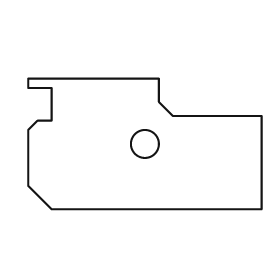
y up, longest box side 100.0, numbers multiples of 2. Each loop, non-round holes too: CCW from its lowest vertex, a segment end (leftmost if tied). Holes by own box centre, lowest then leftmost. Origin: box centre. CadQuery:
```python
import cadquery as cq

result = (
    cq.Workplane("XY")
    .moveTo(-40.0, -28.0)
    .lineTo(50.0, -28.0)
    .lineTo(50.0, 12.0)
    .lineTo(12.0, 12.0)
    .lineTo(6.0, 18.0)
    .lineTo(6.0, 28.0)
    .lineTo(-50.0, 28.0)
    .lineTo(-50.0, 24.0)
    .lineTo(-40.0, 24.0)
    .lineTo(-40.0, 10.0)
    .lineTo(-46.0, 10.0)
    .lineTo(-50.0, 6.0)
    .lineTo(-50.0, -18.0)
    .close()
    .moveTo(0.0, 0.0)
    .circle(6.0)
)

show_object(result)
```